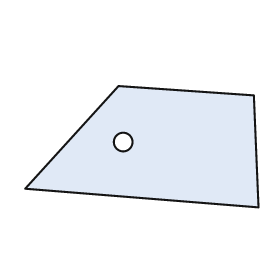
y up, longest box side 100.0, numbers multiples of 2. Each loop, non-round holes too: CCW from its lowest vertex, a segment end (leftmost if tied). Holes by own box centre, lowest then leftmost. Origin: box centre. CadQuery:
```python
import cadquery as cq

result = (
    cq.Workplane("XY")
    .moveTo(50.0, -26.0)
    .lineTo(48.0, 22.0)
    .lineTo(-10.0, 26.0)
    .lineTo(-50.0, -18.0)
    .close()
    .moveTo(-8.0, 2.0)
    .circle(4.0)
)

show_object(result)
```